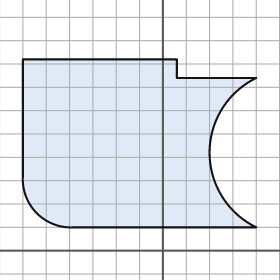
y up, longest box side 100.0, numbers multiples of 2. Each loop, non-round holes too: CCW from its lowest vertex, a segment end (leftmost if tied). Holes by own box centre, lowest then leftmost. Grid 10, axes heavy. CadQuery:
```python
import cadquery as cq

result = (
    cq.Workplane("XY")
    .moveTo(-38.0, 10.0)
    .lineTo(40.0, 10.0)
    .threePointArc((20.0, 42.0), (40.0, 74.0))
    .lineTo(6.0, 74.0)
    .lineTo(6.0, 82.0)
    .lineTo(-60.0, 82.0)
    .lineTo(-60.0, 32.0)
    .threePointArc((-54.0, 16.0), (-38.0, 10.0))
    .close()
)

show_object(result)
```